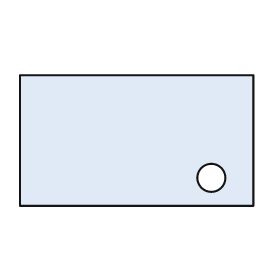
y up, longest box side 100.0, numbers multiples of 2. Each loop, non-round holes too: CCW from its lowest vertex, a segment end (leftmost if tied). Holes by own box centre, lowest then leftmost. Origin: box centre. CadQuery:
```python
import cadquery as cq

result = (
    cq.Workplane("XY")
    .moveTo(-50.0, -28.0)
    .lineTo(50.0, -28.0)
    .lineTo(50.0, 28.0)
    .lineTo(-50.0, 28.0)
    .close()
    .moveTo(32.0, -16.0)
    .circle(6.0)
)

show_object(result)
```